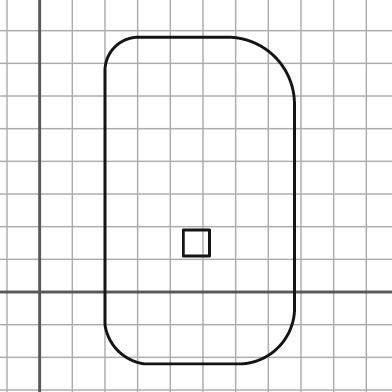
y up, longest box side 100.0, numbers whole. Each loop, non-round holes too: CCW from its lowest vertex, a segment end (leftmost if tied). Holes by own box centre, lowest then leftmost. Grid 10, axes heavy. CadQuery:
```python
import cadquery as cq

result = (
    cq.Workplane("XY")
    .moveTo(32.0, -22.0)
    .lineTo(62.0, -22.0)
    .threePointArc((73.0, -17.0), (78.0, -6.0))
    .lineTo(78.0, 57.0)
    .threePointArc((72.0, 72.0), (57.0, 78.0))
    .lineTo(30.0, 78.0)
    .threePointArc((23.0, 75.0), (20.0, 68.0))
    .lineTo(20.0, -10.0)
    .threePointArc((24.0, -18.0), (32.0, -22.0))
    .close()
    .moveTo(44.0, 11.0)
    .lineTo(52.0, 11.0)
    .lineTo(52.0, 19.0)
    .lineTo(44.0, 19.0)
    .close()
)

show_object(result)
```